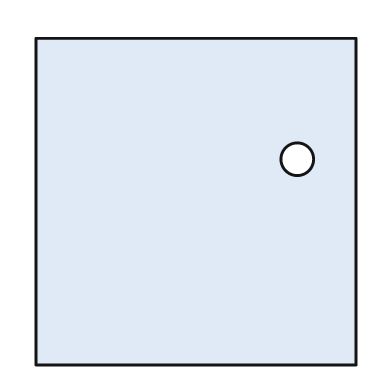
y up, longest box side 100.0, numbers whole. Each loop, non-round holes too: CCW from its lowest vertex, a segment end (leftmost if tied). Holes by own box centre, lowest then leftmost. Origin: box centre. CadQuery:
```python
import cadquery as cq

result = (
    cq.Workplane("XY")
    .moveTo(-49.0, -50.0)
    .lineTo(49.0, -50.0)
    .lineTo(49.0, 50.0)
    .lineTo(-49.0, 50.0)
    .close()
    .moveTo(31.0, 13.0)
    .circle(5.0)
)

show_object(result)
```